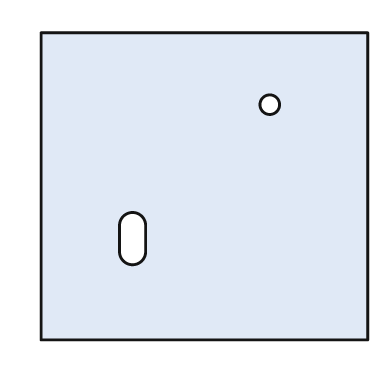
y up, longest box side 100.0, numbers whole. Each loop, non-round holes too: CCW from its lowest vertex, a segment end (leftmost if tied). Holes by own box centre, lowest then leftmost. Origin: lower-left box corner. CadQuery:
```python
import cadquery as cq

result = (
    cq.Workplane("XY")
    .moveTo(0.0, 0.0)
    .lineTo(100.0, 0.0)
    .lineTo(100.0, 94.0)
    .lineTo(0.0, 94.0)
    .close()
    .moveTo(24.0, 27.0)
    .threePointArc((28.0, 23.0), (32.0, 27.0))
    .lineTo(32.0, 35.0)
    .threePointArc((28.0, 39.0), (24.0, 35.0))
    .close()
    .moveTo(70.0, 72.0)
    .circle(3.0)
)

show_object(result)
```